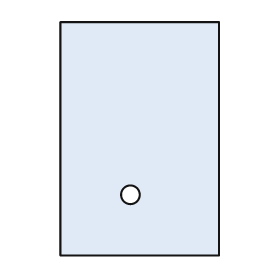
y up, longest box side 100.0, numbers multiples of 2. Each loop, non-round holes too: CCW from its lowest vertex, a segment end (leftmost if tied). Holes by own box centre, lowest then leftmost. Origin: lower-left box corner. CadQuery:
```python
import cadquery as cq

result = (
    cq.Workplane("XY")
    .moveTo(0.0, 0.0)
    .lineTo(68.0, 0.0)
    .lineTo(68.0, 100.0)
    .lineTo(0.0, 100.0)
    .close()
    .moveTo(30.0, 26.0)
    .circle(4.0)
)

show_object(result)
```